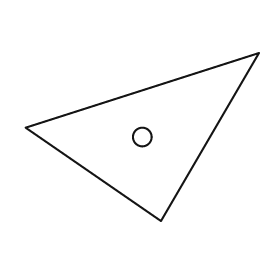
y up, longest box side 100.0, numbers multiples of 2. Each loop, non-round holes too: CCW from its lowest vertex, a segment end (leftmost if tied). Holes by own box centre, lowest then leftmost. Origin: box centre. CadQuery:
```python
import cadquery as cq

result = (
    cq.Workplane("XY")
    .moveTo(8.0, -36.0)
    .lineTo(50.0, 36.0)
    .lineTo(-50.0, 4.0)
    .close()
    .moveTo(0.0, 0.0)
    .circle(4.0)
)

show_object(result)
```